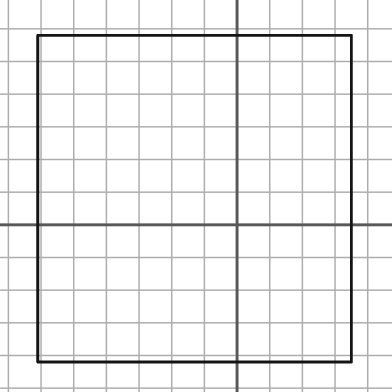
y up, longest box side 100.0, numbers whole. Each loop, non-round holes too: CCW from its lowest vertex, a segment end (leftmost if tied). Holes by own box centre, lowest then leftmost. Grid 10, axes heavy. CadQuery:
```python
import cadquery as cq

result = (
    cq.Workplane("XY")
    .moveTo(-61.0, -42.0)
    .lineTo(35.0, -42.0)
    .lineTo(35.0, 58.0)
    .lineTo(-61.0, 58.0)
    .close()
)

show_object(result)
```